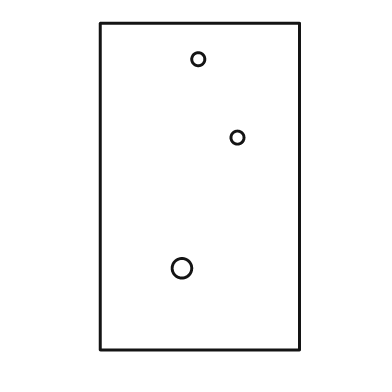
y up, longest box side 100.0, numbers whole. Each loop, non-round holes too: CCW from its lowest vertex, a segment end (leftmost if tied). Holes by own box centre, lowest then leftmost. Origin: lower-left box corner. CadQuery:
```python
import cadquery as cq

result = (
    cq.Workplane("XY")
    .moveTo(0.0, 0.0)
    .lineTo(61.0, 0.0)
    .lineTo(61.0, 100.0)
    .lineTo(0.0, 100.0)
    .close()
    .moveTo(25.0, 25.0)
    .circle(3.0)
    .moveTo(42.0, 65.0)
    .circle(2.0)
    .moveTo(30.0, 89.0)
    .circle(2.0)
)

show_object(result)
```